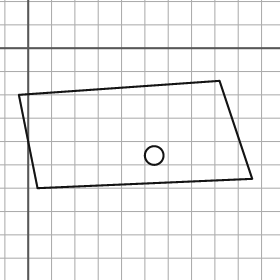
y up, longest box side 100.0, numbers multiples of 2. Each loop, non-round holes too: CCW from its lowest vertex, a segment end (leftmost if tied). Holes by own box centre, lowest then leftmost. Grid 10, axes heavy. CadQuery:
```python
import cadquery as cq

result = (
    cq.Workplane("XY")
    .moveTo(4.0, -60.0)
    .lineTo(96.0, -56.0)
    .lineTo(82.0, -14.0)
    .lineTo(-4.0, -20.0)
    .close()
    .moveTo(54.0, -46.0)
    .circle(4.0)
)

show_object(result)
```